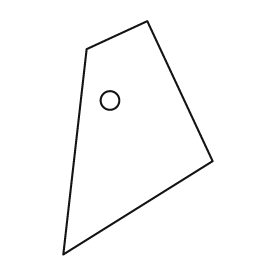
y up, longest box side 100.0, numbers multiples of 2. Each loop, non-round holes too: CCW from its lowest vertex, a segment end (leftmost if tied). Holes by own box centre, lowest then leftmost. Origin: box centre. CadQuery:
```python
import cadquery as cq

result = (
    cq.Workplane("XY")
    .moveTo(-32.0, -50.0)
    .lineTo(32.0, -10.0)
    .lineTo(4.0, 50.0)
    .lineTo(-22.0, 38.0)
    .close()
    .moveTo(-12.0, 16.0)
    .circle(4.0)
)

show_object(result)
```